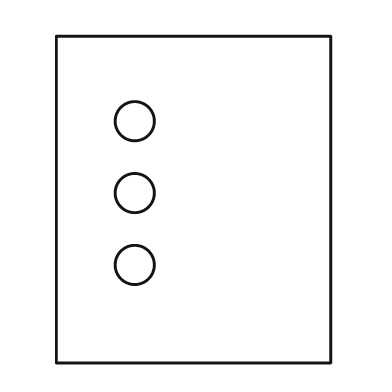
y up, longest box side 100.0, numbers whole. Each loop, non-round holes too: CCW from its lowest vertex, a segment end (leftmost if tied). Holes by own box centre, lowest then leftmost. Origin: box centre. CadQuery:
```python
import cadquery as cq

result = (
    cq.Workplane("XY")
    .moveTo(-42.0, -50.0)
    .lineTo(42.0, -50.0)
    .lineTo(42.0, 50.0)
    .lineTo(-42.0, 50.0)
    .close()
    .moveTo(-18.0, -20.0)
    .circle(6.0)
    .moveTo(-18.0, 2.0)
    .circle(6.0)
    .moveTo(-18.0, 24.0)
    .circle(6.0)
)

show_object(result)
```